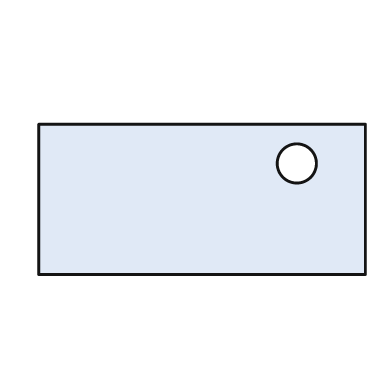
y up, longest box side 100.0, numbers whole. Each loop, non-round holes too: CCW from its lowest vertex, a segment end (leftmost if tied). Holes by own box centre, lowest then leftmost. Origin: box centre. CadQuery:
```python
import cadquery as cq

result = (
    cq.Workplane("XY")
    .moveTo(-50.0, -23.0)
    .lineTo(50.0, -23.0)
    .lineTo(50.0, 23.0)
    .lineTo(-50.0, 23.0)
    .close()
    .moveTo(29.0, 11.0)
    .circle(6.0)
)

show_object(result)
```